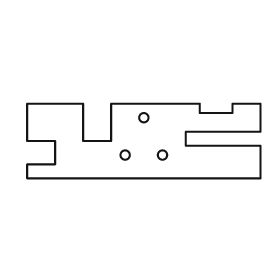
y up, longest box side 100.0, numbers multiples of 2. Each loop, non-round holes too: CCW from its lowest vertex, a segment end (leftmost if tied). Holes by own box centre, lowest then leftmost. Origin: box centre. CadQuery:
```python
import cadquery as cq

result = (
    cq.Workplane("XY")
    .moveTo(-50.0, -16.0)
    .lineTo(50.0, -16.0)
    .lineTo(50.0, -2.0)
    .lineTo(18.0, -2.0)
    .lineTo(18.0, 4.0)
    .lineTo(50.0, 4.0)
    .lineTo(50.0, 16.0)
    .lineTo(38.0, 16.0)
    .lineTo(38.0, 12.0)
    .lineTo(24.0, 12.0)
    .lineTo(24.0, 16.0)
    .lineTo(-14.0, 16.0)
    .lineTo(-14.0, 0.0)
    .lineTo(-26.0, 0.0)
    .lineTo(-26.0, 16.0)
    .lineTo(-50.0, 16.0)
    .lineTo(-50.0, 0.0)
    .lineTo(-38.0, 0.0)
    .lineTo(-38.0, -10.0)
    .lineTo(-50.0, -10.0)
    .close()
    .moveTo(-8.0, -6.0)
    .circle(2.0)
    .moveTo(8.0, -6.0)
    .circle(2.0)
    .moveTo(0.0, 10.0)
    .circle(2.0)
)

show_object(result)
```